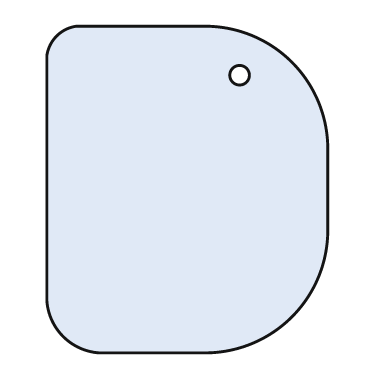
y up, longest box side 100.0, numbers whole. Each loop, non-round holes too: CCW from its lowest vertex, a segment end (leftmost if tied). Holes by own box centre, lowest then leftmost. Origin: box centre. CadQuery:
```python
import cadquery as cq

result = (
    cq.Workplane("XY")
    .moveTo(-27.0, -50.0)
    .lineTo(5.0, -50.0)
    .threePointArc((32.0, -39.0), (43.0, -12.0))
    .lineTo(43.0, 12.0)
    .threePointArc((32.0, 39.0), (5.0, 50.0))
    .lineTo(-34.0, 50.0)
    .threePointArc((-40.0, 47.0), (-43.0, 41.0))
    .lineTo(-43.0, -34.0)
    .threePointArc((-38.0, -45.0), (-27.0, -50.0))
    .close()
    .moveTo(16.0, 35.0)
    .circle(3.0)
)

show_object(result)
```